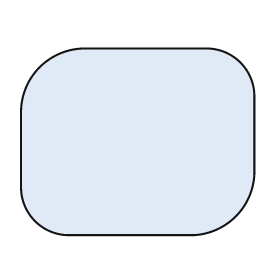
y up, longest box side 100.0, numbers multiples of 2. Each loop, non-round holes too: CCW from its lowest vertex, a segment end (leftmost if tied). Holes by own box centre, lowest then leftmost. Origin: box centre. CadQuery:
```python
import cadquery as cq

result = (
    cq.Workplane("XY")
    .moveTo(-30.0, -40.0)
    .lineTo(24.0, -40.0)
    .threePointArc((42.0, -32.0), (50.0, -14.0))
    .lineTo(50.0, 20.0)
    .threePointArc((44.0, 34.0), (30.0, 40.0))
    .lineTo(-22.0, 40.0)
    .threePointArc((-42.0, 32.0), (-50.0, 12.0))
    .lineTo(-50.0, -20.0)
    .threePointArc((-44.0, -34.0), (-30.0, -40.0))
    .close()
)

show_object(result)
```